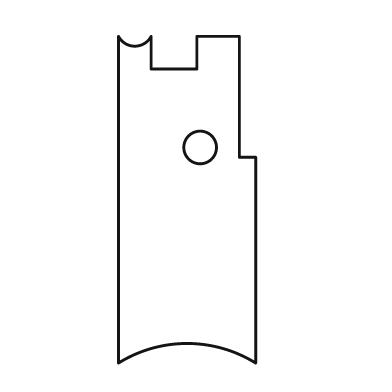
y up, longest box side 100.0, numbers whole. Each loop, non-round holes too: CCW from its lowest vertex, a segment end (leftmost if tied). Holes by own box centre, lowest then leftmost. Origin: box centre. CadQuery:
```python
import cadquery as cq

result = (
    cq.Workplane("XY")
    .moveTo(-21.0, -50.0)
    .threePointArc((0.0, -44.0), (21.0, -50.0))
    .lineTo(21.0, 13.0)
    .lineTo(16.0, 13.0)
    .lineTo(16.0, 50.0)
    .lineTo(3.0, 50.0)
    .lineTo(3.0, 40.0)
    .lineTo(-11.0, 40.0)
    .lineTo(-11.0, 50.0)
    .threePointArc((-16.0, 47.0), (-21.0, 50.0))
    .close()
    .moveTo(4.0, 16.0)
    .circle(5.0)
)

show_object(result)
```